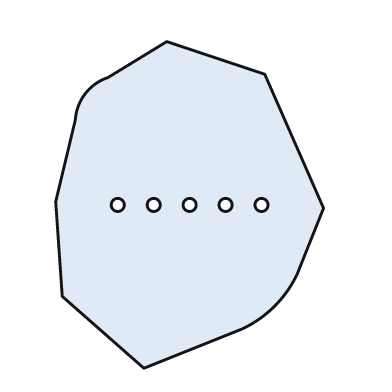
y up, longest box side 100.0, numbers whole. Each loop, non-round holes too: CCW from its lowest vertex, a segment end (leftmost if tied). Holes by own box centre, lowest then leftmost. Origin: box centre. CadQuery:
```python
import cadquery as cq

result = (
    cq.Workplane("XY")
    .moveTo(-14.0, -50.0)
    .lineTo(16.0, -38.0)
    .threePointArc((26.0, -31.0), (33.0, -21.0))
    .lineTo(41.0, -1.0)
    .lineTo(23.0, 40.0)
    .lineTo(-7.0, 50.0)
    .lineTo(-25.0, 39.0)
    .threePointArc((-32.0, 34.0), (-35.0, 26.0))
    .lineTo(-41.0, 1.0)
    .lineTo(-39.0, -28.0)
    .close()
    .moveTo(-22.0, 0.0)
    .circle(2.0)
    .moveTo(-11.0, 0.0)
    .circle(2.0)
    .moveTo(0.0, 0.0)
    .circle(2.0)
    .moveTo(11.0, 0.0)
    .circle(2.0)
    .moveTo(22.0, 0.0)
    .circle(2.0)
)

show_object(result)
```